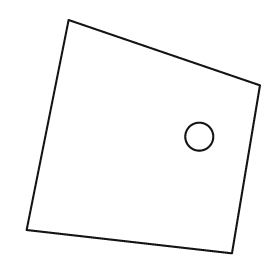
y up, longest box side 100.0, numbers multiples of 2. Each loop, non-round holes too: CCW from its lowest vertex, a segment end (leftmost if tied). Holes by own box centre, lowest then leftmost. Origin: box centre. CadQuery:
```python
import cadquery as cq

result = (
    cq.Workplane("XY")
    .moveTo(38.0, -50.0)
    .lineTo(50.0, 22.0)
    .lineTo(-32.0, 50.0)
    .lineTo(-50.0, -40.0)
    .close()
    .moveTo(24.0, 0.0)
    .circle(6.0)
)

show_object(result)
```